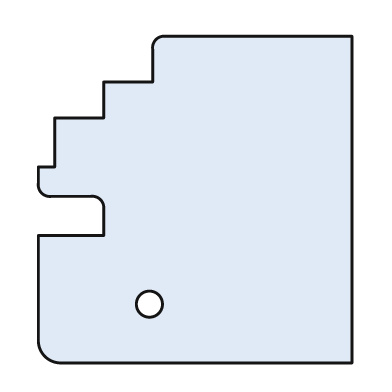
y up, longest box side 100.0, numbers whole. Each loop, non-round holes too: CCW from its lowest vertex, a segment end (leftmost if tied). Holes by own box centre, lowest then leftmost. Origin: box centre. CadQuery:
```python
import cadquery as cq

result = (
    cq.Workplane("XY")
    .moveTo(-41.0, -50.0)
    .lineTo(48.0, -50.0)
    .lineTo(48.0, 50.0)
    .lineTo(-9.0, 50.0)
    .threePointArc((-12.0, 49.0), (-13.0, 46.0))
    .lineTo(-13.0, 36.0)
    .lineTo(-28.0, 36.0)
    .lineTo(-28.0, 25.0)
    .lineTo(-43.0, 25.0)
    .lineTo(-43.0, 10.0)
    .lineTo(-48.0, 10.0)
    .lineTo(-48.0, 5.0)
    .threePointArc((-47.0, 2.0), (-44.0, 1.0))
    .lineTo(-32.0, 1.0)
    .threePointArc((-29.0, 0.0), (-28.0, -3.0))
    .lineTo(-28.0, -11.0)
    .lineTo(-48.0, -11.0)
    .lineTo(-48.0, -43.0)
    .threePointArc((-46.0, -48.0), (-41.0, -50.0))
    .close()
    .moveTo(-14.0, -32.0)
    .circle(4.0)
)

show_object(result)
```